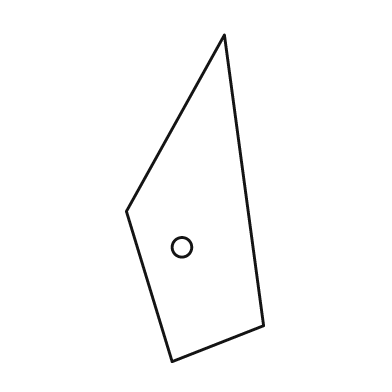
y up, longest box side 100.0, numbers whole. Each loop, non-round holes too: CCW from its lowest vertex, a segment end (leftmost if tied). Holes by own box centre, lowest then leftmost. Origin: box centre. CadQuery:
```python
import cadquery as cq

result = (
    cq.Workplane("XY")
    .moveTo(-7.0, -50.0)
    .lineTo(21.0, -39.0)
    .lineTo(9.0, 50.0)
    .lineTo(-21.0, -4.0)
    .close()
    .moveTo(-4.0, -15.0)
    .circle(3.0)
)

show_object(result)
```